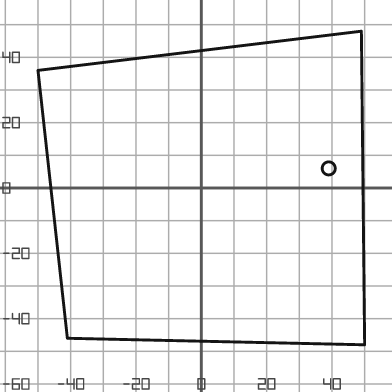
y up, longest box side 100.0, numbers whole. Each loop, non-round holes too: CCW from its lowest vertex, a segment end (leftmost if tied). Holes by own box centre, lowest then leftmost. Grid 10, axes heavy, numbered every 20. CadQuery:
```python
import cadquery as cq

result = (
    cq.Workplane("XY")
    .moveTo(50.0, -48.0)
    .lineTo(49.0, 48.0)
    .lineTo(-50.0, 36.0)
    .lineTo(-41.0, -46.0)
    .close()
    .moveTo(39.0, 6.0)
    .circle(2.0)
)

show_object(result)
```